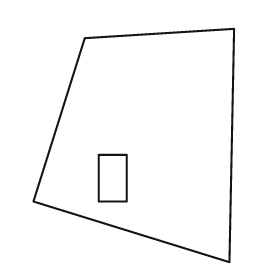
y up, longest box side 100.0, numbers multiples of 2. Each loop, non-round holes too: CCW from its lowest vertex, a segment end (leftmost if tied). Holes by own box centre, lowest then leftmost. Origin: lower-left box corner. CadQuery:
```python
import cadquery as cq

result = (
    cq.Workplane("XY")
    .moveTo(84.0, 0.0)
    .lineTo(86.0, 100.0)
    .lineTo(22.0, 96.0)
    .lineTo(0.0, 26.0)
    .close()
    .moveTo(28.0, 26.0)
    .lineTo(40.0, 26.0)
    .lineTo(40.0, 46.0)
    .lineTo(28.0, 46.0)
    .close()
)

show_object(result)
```